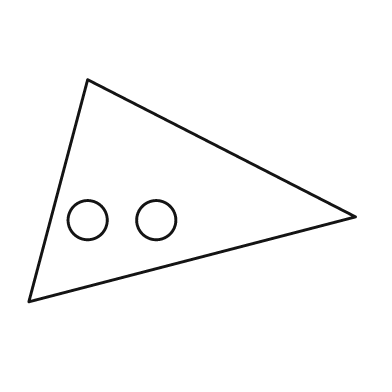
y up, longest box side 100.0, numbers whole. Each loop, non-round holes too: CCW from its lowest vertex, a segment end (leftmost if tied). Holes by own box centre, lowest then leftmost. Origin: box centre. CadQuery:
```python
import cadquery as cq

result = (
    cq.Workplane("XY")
    .moveTo(-50.0, -34.0)
    .lineTo(50.0, -8.0)
    .lineTo(-32.0, 34.0)
    .close()
    .moveTo(-32.0, -9.0)
    .circle(6.0)
    .moveTo(-11.0, -9.0)
    .circle(6.0)
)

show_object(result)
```